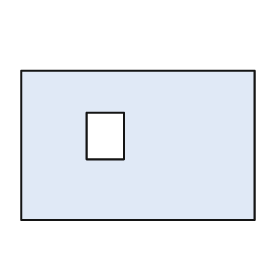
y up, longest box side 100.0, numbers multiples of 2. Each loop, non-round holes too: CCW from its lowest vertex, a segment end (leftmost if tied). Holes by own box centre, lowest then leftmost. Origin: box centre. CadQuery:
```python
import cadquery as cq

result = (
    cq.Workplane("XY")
    .moveTo(-50.0, -32.0)
    .lineTo(50.0, -32.0)
    .lineTo(50.0, 32.0)
    .lineTo(-50.0, 32.0)
    .close()
    .moveTo(-22.0, -6.0)
    .lineTo(-6.0, -6.0)
    .lineTo(-6.0, 14.0)
    .lineTo(-22.0, 14.0)
    .close()
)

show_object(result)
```